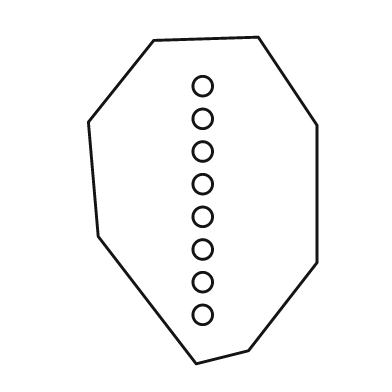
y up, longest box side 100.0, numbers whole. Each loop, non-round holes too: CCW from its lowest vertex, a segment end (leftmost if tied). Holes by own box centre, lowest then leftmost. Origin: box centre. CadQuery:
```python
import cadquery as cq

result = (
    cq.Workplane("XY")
    .moveTo(-2.0, -50.0)
    .lineTo(14.0, -46.0)
    .lineTo(35.0, -19.0)
    .lineTo(35.0, 23.0)
    .lineTo(17.0, 50.0)
    .lineTo(-15.0, 49.0)
    .lineTo(-35.0, 24.0)
    .lineTo(-32.0, -11.0)
    .close()
    .moveTo(0.0, -35.0)
    .circle(3.0)
    .moveTo(0.0, -25.0)
    .circle(3.0)
    .moveTo(0.0, -15.0)
    .circle(3.0)
    .moveTo(0.0, -5.0)
    .circle(3.0)
    .moveTo(0.0, 5.0)
    .circle(3.0)
    .moveTo(0.0, 15.0)
    .circle(3.0)
    .moveTo(0.0, 25.0)
    .circle(3.0)
    .moveTo(0.0, 35.0)
    .circle(3.0)
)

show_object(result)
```